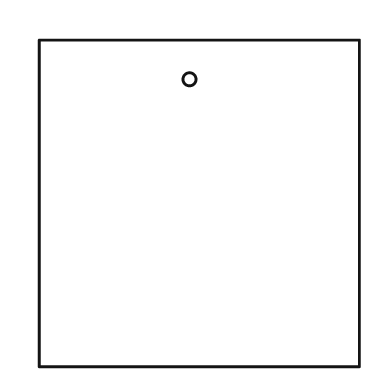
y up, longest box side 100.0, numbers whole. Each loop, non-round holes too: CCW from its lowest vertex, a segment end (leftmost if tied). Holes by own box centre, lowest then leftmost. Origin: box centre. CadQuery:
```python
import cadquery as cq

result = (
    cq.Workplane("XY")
    .moveTo(-49.0, -50.0)
    .lineTo(49.0, -50.0)
    .lineTo(49.0, 50.0)
    .lineTo(-49.0, 50.0)
    .close()
    .moveTo(-3.0, 38.0)
    .circle(2.0)
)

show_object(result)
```